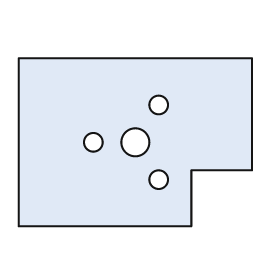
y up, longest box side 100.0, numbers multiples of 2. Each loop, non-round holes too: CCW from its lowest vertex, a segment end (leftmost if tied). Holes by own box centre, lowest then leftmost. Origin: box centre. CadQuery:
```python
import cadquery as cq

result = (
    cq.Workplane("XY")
    .moveTo(-50.0, -36.0)
    .lineTo(24.0, -36.0)
    .lineTo(24.0, -12.0)
    .lineTo(50.0, -12.0)
    .lineTo(50.0, 36.0)
    .lineTo(-50.0, 36.0)
    .close()
    .moveTo(10.0, -16.0)
    .circle(4.0)
    .moveTo(-18.0, 0.0)
    .circle(4.0)
    .moveTo(0.0, 0.0)
    .circle(6.0)
    .moveTo(10.0, 16.0)
    .circle(4.0)
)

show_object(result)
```